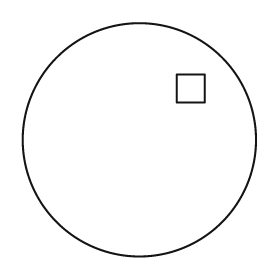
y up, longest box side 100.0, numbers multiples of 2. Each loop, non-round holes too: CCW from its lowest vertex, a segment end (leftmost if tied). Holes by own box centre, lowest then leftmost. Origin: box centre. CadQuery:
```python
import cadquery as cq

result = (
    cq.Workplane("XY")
    .moveTo(0.0, 0.0)
    .circle(50.0)
    .moveTo(16.0, 16.0)
    .lineTo(28.0, 16.0)
    .lineTo(28.0, 28.0)
    .lineTo(16.0, 28.0)
    .close()
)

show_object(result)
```